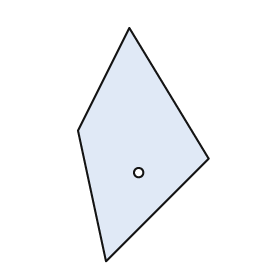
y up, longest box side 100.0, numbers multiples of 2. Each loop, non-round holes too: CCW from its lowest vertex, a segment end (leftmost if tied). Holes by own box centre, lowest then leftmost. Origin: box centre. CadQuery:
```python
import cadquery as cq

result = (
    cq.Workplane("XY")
    .moveTo(-16.0, -50.0)
    .lineTo(28.0, -6.0)
    .lineTo(-6.0, 50.0)
    .lineTo(-28.0, 6.0)
    .close()
    .moveTo(-2.0, -12.0)
    .circle(2.0)
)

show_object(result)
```